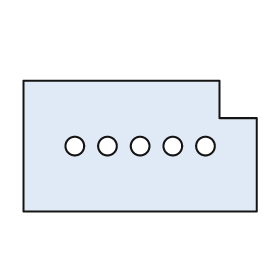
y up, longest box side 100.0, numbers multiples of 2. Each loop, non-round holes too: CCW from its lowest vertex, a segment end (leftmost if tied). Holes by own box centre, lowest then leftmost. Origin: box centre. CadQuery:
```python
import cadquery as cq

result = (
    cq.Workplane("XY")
    .moveTo(-50.0, -28.0)
    .lineTo(50.0, -28.0)
    .lineTo(50.0, 12.0)
    .lineTo(34.0, 12.0)
    .lineTo(34.0, 28.0)
    .lineTo(-50.0, 28.0)
    .close()
    .moveTo(-28.0, 0.0)
    .circle(4.0)
    .moveTo(-14.0, 0.0)
    .circle(4.0)
    .moveTo(0.0, 0.0)
    .circle(4.0)
    .moveTo(14.0, 0.0)
    .circle(4.0)
    .moveTo(28.0, 0.0)
    .circle(4.0)
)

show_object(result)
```